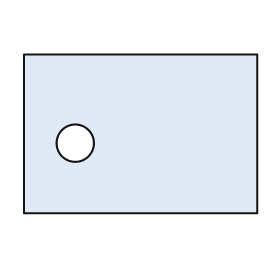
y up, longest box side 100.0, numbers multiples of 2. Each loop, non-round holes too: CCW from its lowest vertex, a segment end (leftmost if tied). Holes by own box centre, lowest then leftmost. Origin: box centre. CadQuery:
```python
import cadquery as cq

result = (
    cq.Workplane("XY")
    .moveTo(-50.0, -34.0)
    .lineTo(50.0, -34.0)
    .lineTo(50.0, 34.0)
    .lineTo(-50.0, 34.0)
    .close()
    .moveTo(-28.0, -4.0)
    .circle(8.0)
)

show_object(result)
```